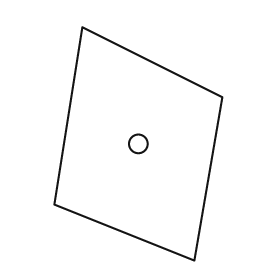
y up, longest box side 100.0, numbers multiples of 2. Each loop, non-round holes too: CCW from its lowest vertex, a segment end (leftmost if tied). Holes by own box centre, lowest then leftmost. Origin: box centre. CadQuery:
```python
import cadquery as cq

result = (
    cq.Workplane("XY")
    .moveTo(24.0, -50.0)
    .lineTo(36.0, 20.0)
    .lineTo(-24.0, 50.0)
    .lineTo(-36.0, -26.0)
    .close()
    .moveTo(0.0, 0.0)
    .circle(4.0)
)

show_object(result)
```